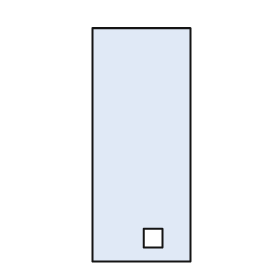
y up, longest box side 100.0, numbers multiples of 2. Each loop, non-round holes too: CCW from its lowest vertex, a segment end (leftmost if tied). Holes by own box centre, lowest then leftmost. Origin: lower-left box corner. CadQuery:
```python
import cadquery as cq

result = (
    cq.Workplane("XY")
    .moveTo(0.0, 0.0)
    .lineTo(42.0, 0.0)
    .lineTo(42.0, 100.0)
    .lineTo(0.0, 100.0)
    .close()
    .moveTo(22.0, 6.0)
    .lineTo(30.0, 6.0)
    .lineTo(30.0, 14.0)
    .lineTo(22.0, 14.0)
    .close()
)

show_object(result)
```